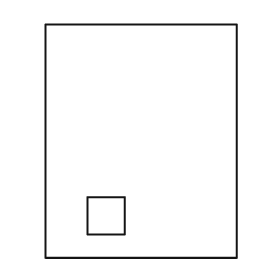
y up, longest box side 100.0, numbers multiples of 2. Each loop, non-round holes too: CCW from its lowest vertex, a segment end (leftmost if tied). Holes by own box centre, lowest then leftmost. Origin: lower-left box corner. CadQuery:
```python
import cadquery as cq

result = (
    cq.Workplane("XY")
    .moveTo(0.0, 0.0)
    .lineTo(82.0, 0.0)
    .lineTo(82.0, 100.0)
    .lineTo(0.0, 100.0)
    .close()
    .moveTo(18.0, 10.0)
    .lineTo(34.0, 10.0)
    .lineTo(34.0, 26.0)
    .lineTo(18.0, 26.0)
    .close()
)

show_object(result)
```